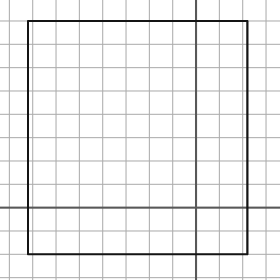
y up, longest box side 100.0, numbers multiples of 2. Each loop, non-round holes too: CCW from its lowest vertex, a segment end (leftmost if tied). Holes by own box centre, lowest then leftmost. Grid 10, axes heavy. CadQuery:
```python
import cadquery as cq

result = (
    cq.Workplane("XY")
    .moveTo(-72.0, -20.0)
    .lineTo(22.0, -20.0)
    .lineTo(22.0, 80.0)
    .lineTo(-72.0, 80.0)
    .close()
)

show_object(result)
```